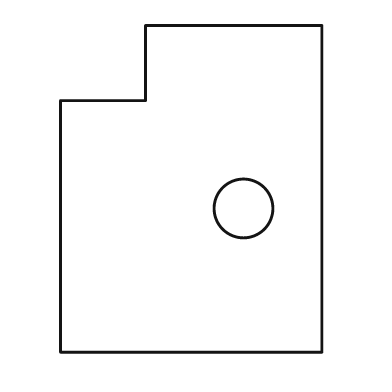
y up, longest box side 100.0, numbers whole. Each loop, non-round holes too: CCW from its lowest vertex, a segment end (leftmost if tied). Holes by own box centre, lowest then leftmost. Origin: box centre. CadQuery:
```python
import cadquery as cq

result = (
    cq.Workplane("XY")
    .moveTo(-40.0, -50.0)
    .lineTo(40.0, -50.0)
    .lineTo(40.0, 50.0)
    .lineTo(-14.0, 50.0)
    .lineTo(-14.0, 27.0)
    .lineTo(-40.0, 27.0)
    .close()
    .moveTo(16.0, -6.0)
    .circle(9.0)
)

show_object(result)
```